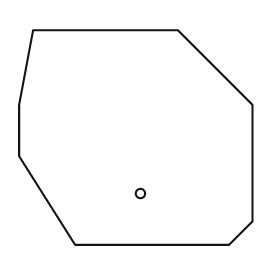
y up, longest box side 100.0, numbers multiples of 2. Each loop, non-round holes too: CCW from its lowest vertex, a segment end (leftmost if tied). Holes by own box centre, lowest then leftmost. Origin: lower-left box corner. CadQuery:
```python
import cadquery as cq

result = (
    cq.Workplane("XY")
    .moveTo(24.0, 0.0)
    .lineTo(90.0, 0.0)
    .lineTo(100.0, 10.0)
    .lineTo(100.0, 60.0)
    .lineTo(68.0, 92.0)
    .lineTo(6.0, 92.0)
    .lineTo(0.0, 60.0)
    .lineTo(0.0, 38.0)
    .close()
    .moveTo(52.0, 22.0)
    .circle(2.0)
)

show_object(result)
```